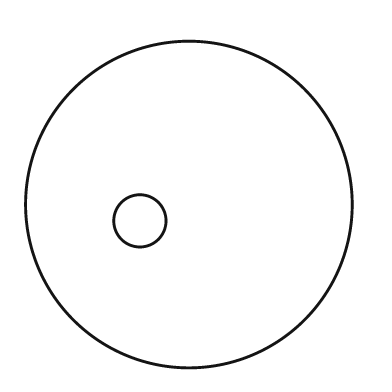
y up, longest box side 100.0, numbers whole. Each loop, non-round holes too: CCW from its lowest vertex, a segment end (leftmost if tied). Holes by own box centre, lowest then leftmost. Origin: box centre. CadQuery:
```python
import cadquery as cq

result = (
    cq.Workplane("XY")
    .moveTo(0.0, 0.0)
    .circle(50.0)
    .moveTo(-15.0, -5.0)
    .circle(8.0)
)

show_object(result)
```